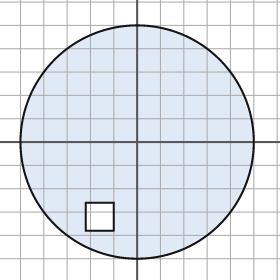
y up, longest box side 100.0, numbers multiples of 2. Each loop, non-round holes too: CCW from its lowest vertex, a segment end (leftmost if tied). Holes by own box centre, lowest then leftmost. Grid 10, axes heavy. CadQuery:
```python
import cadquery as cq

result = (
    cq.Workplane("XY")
    .moveTo(0.0, 0.0)
    .circle(50.0)
    .moveTo(-22.0, -38.0)
    .lineTo(-10.0, -38.0)
    .lineTo(-10.0, -26.0)
    .lineTo(-22.0, -26.0)
    .close()
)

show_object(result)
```